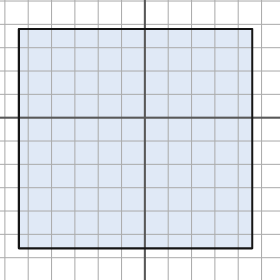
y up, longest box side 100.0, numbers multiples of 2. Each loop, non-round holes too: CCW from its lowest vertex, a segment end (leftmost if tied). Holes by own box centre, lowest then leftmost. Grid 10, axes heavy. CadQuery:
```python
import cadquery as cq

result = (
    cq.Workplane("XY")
    .moveTo(-54.0, -56.0)
    .lineTo(46.0, -56.0)
    .lineTo(46.0, 38.0)
    .lineTo(-54.0, 38.0)
    .close()
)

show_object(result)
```